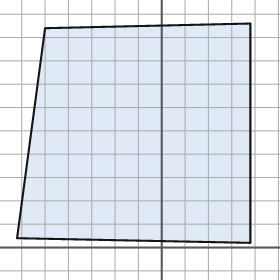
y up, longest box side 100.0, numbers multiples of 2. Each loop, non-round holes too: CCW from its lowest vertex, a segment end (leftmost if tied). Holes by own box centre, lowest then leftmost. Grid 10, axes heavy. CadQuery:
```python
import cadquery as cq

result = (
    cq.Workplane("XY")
    .moveTo(38.0, 2.0)
    .lineTo(38.0, 96.0)
    .lineTo(-50.0, 94.0)
    .lineTo(-62.0, 4.0)
    .close()
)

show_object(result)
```